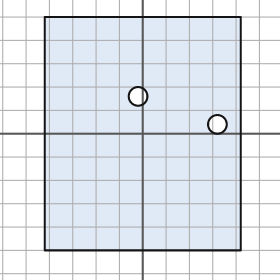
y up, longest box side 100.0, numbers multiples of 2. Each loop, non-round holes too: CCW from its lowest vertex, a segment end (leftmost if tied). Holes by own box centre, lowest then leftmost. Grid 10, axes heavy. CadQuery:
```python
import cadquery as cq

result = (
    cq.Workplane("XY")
    .moveTo(-42.0, -50.0)
    .lineTo(42.0, -50.0)
    .lineTo(42.0, 50.0)
    .lineTo(-42.0, 50.0)
    .close()
    .moveTo(32.0, 4.0)
    .circle(4.0)
    .moveTo(-2.0, 16.0)
    .circle(4.0)
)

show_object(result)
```